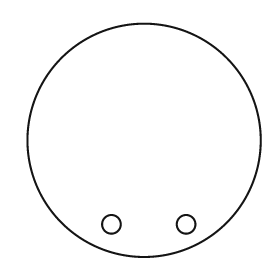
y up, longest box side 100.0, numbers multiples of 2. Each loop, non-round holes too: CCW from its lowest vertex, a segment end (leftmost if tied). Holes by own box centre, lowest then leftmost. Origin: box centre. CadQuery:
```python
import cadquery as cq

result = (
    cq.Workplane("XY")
    .moveTo(0.0, 0.0)
    .circle(50.0)
    .moveTo(-14.0, -36.0)
    .circle(4.0)
    .moveTo(18.0, -36.0)
    .circle(4.0)
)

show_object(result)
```